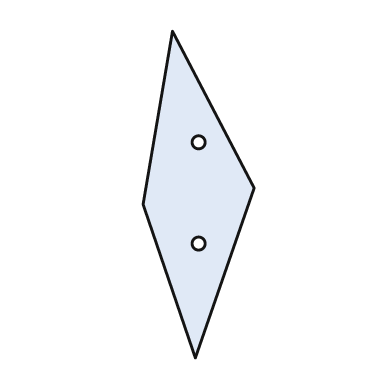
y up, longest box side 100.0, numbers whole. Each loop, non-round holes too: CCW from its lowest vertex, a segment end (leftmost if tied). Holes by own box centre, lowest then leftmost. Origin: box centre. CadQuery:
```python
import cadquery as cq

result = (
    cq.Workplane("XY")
    .moveTo(-1.0, -50.0)
    .lineTo(17.0, 2.0)
    .lineTo(-8.0, 50.0)
    .lineTo(-17.0, -3.0)
    .close()
    .moveTo(0.0, -15.0)
    .circle(2.0)
    .moveTo(0.0, 16.0)
    .circle(2.0)
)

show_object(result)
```